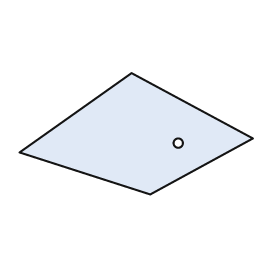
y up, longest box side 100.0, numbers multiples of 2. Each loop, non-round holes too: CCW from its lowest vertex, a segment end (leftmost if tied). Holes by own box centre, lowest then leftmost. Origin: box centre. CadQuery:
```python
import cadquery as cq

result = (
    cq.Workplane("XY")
    .moveTo(6.0, -26.0)
    .lineTo(50.0, -2.0)
    .lineTo(-2.0, 26.0)
    .lineTo(-50.0, -8.0)
    .close()
    .moveTo(18.0, -4.0)
    .circle(2.0)
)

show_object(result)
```